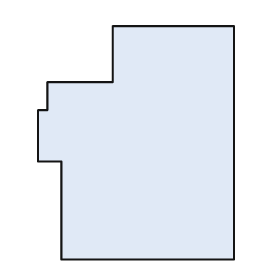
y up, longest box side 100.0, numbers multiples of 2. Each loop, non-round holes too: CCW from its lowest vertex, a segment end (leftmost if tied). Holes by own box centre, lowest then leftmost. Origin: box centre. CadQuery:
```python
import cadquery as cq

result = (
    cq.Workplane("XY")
    .moveTo(-32.0, -50.0)
    .lineTo(42.0, -50.0)
    .lineTo(42.0, 50.0)
    .lineTo(-10.0, 50.0)
    .lineTo(-10.0, 26.0)
    .lineTo(-38.0, 26.0)
    .lineTo(-38.0, 14.0)
    .lineTo(-42.0, 14.0)
    .lineTo(-42.0, -8.0)
    .lineTo(-32.0, -8.0)
    .close()
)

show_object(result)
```